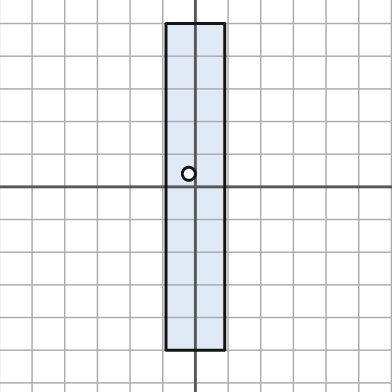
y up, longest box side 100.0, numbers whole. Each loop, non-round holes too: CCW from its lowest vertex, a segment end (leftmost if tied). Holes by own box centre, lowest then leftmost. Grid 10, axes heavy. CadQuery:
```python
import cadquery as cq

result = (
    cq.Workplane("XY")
    .moveTo(-9.0, -50.0)
    .lineTo(9.0, -50.0)
    .lineTo(9.0, 50.0)
    .lineTo(-9.0, 50.0)
    .close()
    .moveTo(-2.0, 4.0)
    .circle(2.0)
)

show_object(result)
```